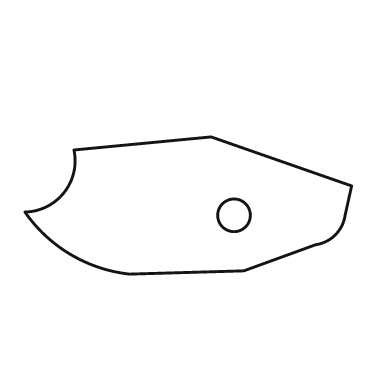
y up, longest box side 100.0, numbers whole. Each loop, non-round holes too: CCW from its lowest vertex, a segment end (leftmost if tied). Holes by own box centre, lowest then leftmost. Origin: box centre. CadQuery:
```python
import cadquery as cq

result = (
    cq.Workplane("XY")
    .moveTo(-18.0, -21.0)
    .lineTo(17.0, -20.0)
    .lineTo(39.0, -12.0)
    .threePointArc((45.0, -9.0), (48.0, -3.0))
    .lineTo(50.0, 6.0)
    .lineTo(7.0, 21.0)
    .lineTo(-35.0, 17.0)
    .threePointArc((-38.0, 4.0), (-50.0, -2.0))
    .threePointArc((-36.0, -15.0), (-18.0, -21.0))
    .close()
    .moveTo(14.0, -3.0)
    .circle(5.0)
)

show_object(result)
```